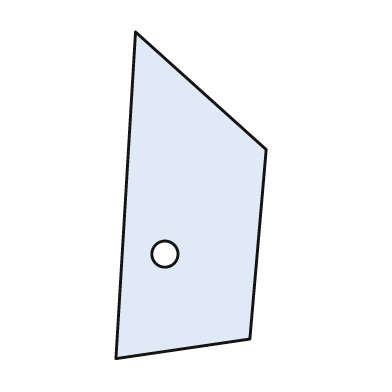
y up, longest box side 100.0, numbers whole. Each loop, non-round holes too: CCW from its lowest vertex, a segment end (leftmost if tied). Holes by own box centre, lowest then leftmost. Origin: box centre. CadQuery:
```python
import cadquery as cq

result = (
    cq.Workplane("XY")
    .moveTo(-23.0, -50.0)
    .lineTo(18.0, -44.0)
    .lineTo(23.0, 14.0)
    .lineTo(-17.0, 50.0)
    .close()
    .moveTo(-8.0, -18.0)
    .circle(4.0)
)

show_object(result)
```